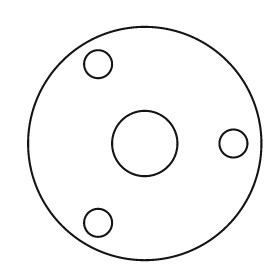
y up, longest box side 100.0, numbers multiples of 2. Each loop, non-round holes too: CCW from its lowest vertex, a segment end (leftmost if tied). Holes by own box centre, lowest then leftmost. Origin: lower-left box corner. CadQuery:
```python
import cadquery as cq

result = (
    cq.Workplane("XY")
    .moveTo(50.0, 50.0)
    .circle(50.0)
    .moveTo(30.0, 16.0)
    .circle(6.0)
    .moveTo(50.0, 50.0)
    .circle(14.0)
    .moveTo(88.0, 50.0)
    .circle(6.0)
    .moveTo(30.0, 84.0)
    .circle(6.0)
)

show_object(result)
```